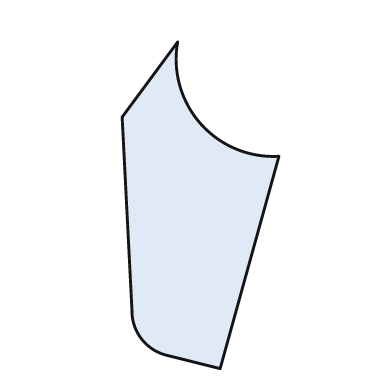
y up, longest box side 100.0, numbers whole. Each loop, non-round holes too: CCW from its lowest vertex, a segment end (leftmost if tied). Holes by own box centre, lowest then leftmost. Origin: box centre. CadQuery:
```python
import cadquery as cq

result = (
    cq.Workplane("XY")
    .moveTo(6.0, -50.0)
    .lineTo(24.0, 15.0)
    .threePointArc((0.0, 25.0), (-7.0, 50.0))
    .lineTo(-24.0, 27.0)
    .lineTo(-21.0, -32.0)
    .threePointArc((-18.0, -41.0), (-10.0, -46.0))
    .close()
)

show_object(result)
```